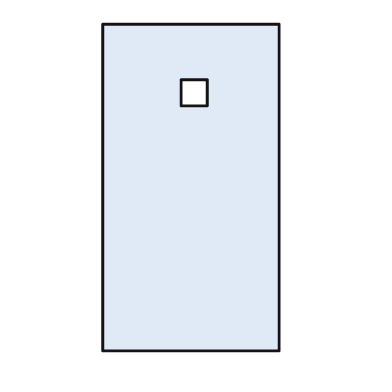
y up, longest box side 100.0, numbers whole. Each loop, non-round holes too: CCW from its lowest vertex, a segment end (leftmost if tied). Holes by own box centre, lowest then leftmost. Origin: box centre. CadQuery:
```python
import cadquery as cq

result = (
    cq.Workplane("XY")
    .moveTo(-27.0, -50.0)
    .lineTo(27.0, -50.0)
    .lineTo(27.0, 50.0)
    .lineTo(-27.0, 50.0)
    .close()
    .moveTo(-3.0, 25.0)
    .lineTo(5.0, 25.0)
    .lineTo(5.0, 33.0)
    .lineTo(-3.0, 33.0)
    .close()
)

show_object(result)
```